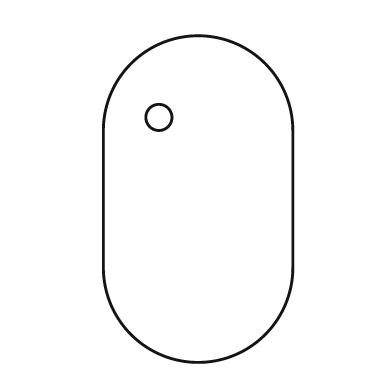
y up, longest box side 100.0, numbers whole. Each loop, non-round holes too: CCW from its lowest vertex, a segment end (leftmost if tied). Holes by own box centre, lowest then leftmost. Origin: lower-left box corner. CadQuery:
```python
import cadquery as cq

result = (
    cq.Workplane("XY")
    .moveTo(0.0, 29.0)
    .threePointArc((29.0, 0.0), (58.0, 29.0))
    .lineTo(58.0, 71.0)
    .threePointArc((29.0, 100.0), (0.0, 71.0))
    .close()
    .moveTo(17.0, 75.0)
    .circle(4.0)
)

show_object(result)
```